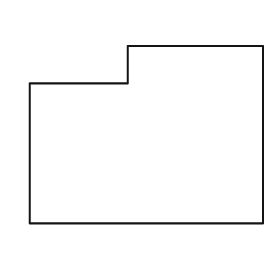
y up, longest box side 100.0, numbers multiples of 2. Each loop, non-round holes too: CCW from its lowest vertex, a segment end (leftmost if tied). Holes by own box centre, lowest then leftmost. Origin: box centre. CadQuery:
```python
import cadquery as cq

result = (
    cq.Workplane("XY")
    .moveTo(-50.0, -38.0)
    .lineTo(50.0, -38.0)
    .lineTo(50.0, 38.0)
    .lineTo(-8.0, 38.0)
    .lineTo(-8.0, 22.0)
    .lineTo(-50.0, 22.0)
    .close()
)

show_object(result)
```